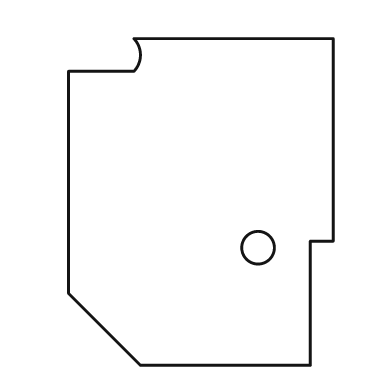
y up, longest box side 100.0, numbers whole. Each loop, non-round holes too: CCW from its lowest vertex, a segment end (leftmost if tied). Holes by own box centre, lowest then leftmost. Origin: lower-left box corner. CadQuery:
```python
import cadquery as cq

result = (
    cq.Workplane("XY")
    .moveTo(22.0, 0.0)
    .lineTo(74.0, 0.0)
    .lineTo(74.0, 38.0)
    .lineTo(81.0, 38.0)
    .lineTo(81.0, 100.0)
    .lineTo(20.0, 100.0)
    .threePointArc((22.0, 95.0), (20.0, 90.0))
    .lineTo(0.0, 90.0)
    .lineTo(0.0, 22.0)
    .close()
    .moveTo(58.0, 36.0)
    .circle(5.0)
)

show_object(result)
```